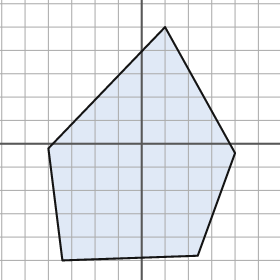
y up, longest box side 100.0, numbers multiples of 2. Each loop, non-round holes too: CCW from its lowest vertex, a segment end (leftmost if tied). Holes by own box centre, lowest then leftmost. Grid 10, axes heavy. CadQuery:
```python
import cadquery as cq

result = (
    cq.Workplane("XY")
    .moveTo(-34.0, -50.0)
    .lineTo(24.0, -48.0)
    .lineTo(40.0, -4.0)
    .lineTo(10.0, 50.0)
    .lineTo(-40.0, -2.0)
    .close()
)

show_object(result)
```